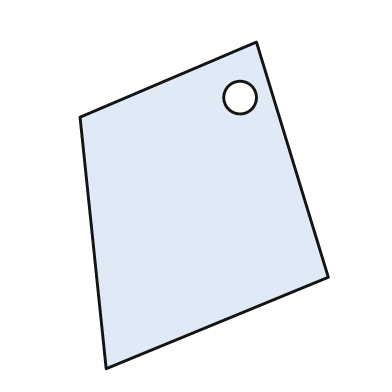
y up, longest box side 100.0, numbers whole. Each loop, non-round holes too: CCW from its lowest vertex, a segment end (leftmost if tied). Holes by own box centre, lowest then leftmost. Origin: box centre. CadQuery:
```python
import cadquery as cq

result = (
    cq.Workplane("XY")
    .moveTo(-30.0, -50.0)
    .lineTo(38.0, -22.0)
    .lineTo(16.0, 50.0)
    .lineTo(-38.0, 27.0)
    .close()
    .moveTo(11.0, 33.0)
    .circle(5.0)
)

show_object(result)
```